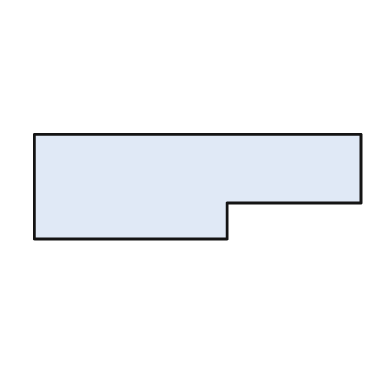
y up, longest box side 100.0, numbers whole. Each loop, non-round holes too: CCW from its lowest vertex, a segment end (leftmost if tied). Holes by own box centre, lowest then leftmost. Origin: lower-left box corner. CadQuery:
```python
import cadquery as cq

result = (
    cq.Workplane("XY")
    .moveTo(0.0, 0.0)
    .lineTo(59.0, 0.0)
    .lineTo(59.0, 11.0)
    .lineTo(100.0, 11.0)
    .lineTo(100.0, 32.0)
    .lineTo(0.0, 32.0)
    .close()
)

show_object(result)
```